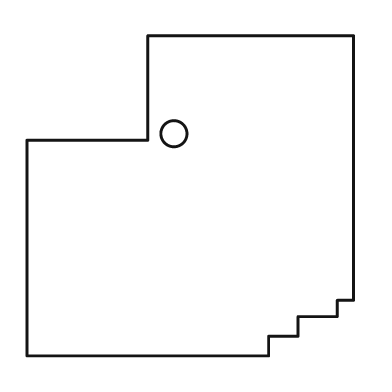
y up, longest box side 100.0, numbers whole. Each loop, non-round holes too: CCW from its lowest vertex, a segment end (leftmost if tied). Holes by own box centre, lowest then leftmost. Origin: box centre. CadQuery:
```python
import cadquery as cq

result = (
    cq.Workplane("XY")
    .moveTo(-50.0, -49.0)
    .lineTo(24.0, -49.0)
    .lineTo(24.0, -43.0)
    .lineTo(33.0, -43.0)
    .lineTo(33.0, -37.0)
    .lineTo(45.0, -37.0)
    .lineTo(45.0, -32.0)
    .lineTo(50.0, -32.0)
    .lineTo(50.0, 49.0)
    .lineTo(-13.0, 49.0)
    .lineTo(-13.0, 17.0)
    .lineTo(-50.0, 17.0)
    .close()
    .moveTo(-5.0, 19.0)
    .circle(4.0)
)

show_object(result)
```